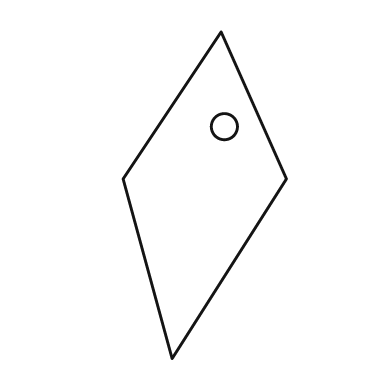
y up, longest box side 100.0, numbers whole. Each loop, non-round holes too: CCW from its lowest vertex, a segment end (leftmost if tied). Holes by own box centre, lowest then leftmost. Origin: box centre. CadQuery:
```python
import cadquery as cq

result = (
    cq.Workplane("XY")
    .moveTo(-10.0, -50.0)
    .lineTo(25.0, 5.0)
    .lineTo(5.0, 50.0)
    .lineTo(-25.0, 5.0)
    .close()
    .moveTo(6.0, 21.0)
    .circle(4.0)
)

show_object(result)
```